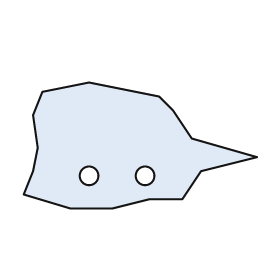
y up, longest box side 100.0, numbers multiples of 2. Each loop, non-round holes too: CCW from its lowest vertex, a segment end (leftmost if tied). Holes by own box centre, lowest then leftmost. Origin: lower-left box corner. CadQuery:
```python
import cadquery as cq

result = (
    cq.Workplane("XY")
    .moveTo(20.0, 0.0)
    .lineTo(38.0, 0.0)
    .lineTo(54.0, 4.0)
    .lineTo(68.0, 4.0)
    .lineTo(76.0, 16.0)
    .lineTo(100.0, 22.0)
    .lineTo(72.0, 30.0)
    .lineTo(64.0, 42.0)
    .lineTo(58.0, 48.0)
    .lineTo(28.0, 54.0)
    .lineTo(8.0, 50.0)
    .lineTo(4.0, 40.0)
    .lineTo(6.0, 26.0)
    .lineTo(4.0, 16.0)
    .lineTo(0.0, 6.0)
    .close()
    .moveTo(28.0, 14.0)
    .circle(4.0)
    .moveTo(52.0, 14.0)
    .circle(4.0)
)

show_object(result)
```